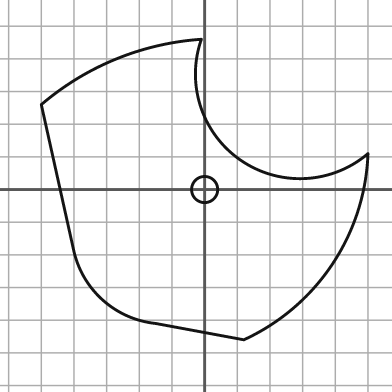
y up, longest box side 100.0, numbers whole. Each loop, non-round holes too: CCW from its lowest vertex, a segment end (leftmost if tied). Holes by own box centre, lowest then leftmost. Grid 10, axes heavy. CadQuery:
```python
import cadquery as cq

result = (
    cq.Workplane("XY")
    .moveTo(12.0, -46.0)
    .threePointArc((39.0, -23.0), (50.0, 11.0))
    .threePointArc((11.0, 9.0), (-1.0, 46.0))
    .threePointArc((-27.0, 40.0), (-50.0, 26.0))
    .lineTo(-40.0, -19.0)
    .threePointArc((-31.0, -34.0), (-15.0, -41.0))
    .close()
    .moveTo(0.0, 0.0)
    .circle(4.0)
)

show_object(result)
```